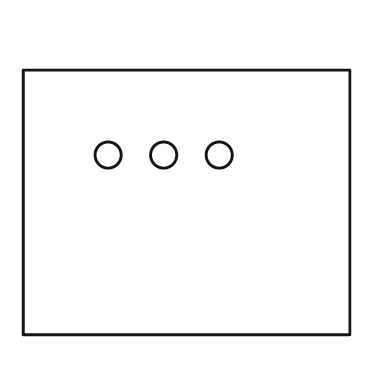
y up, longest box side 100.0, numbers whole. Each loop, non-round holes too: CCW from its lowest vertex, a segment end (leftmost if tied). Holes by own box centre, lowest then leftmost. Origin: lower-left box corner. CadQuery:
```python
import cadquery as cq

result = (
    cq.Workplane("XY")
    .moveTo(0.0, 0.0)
    .lineTo(100.0, 0.0)
    .lineTo(100.0, 81.0)
    .lineTo(0.0, 81.0)
    .close()
    .moveTo(26.0, 55.0)
    .circle(4.0)
    .moveTo(43.0, 55.0)
    .circle(4.0)
    .moveTo(60.0, 55.0)
    .circle(4.0)
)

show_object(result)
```